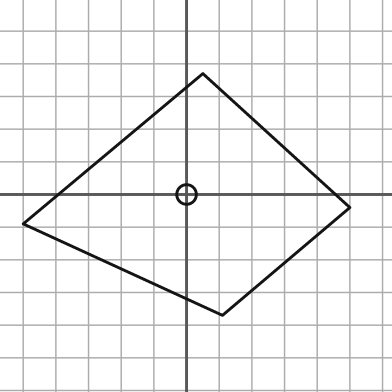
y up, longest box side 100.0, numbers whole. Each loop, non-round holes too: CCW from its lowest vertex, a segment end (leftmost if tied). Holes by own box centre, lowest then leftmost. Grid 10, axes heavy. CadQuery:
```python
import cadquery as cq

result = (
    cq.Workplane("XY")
    .moveTo(11.0, -37.0)
    .lineTo(50.0, -4.0)
    .lineTo(5.0, 37.0)
    .lineTo(-50.0, -9.0)
    .close()
    .moveTo(0.0, 0.0)
    .circle(3.0)
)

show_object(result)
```